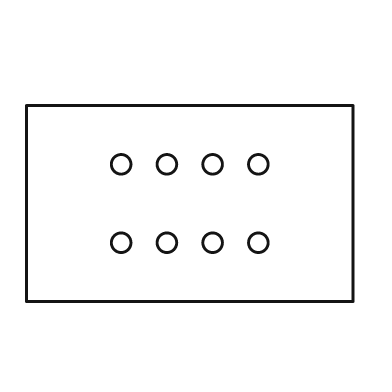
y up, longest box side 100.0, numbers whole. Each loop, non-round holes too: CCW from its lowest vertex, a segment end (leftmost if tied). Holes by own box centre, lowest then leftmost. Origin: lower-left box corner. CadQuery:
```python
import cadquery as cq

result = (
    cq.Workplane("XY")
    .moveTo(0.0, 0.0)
    .lineTo(100.0, 0.0)
    .lineTo(100.0, 60.0)
    .lineTo(0.0, 60.0)
    .close()
    .moveTo(29.0, 18.0)
    .circle(3.0)
    .moveTo(43.0, 18.0)
    .circle(3.0)
    .moveTo(57.0, 18.0)
    .circle(3.0)
    .moveTo(71.0, 18.0)
    .circle(3.0)
    .moveTo(29.0, 42.0)
    .circle(3.0)
    .moveTo(43.0, 42.0)
    .circle(3.0)
    .moveTo(57.0, 42.0)
    .circle(3.0)
    .moveTo(71.0, 42.0)
    .circle(3.0)
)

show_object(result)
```